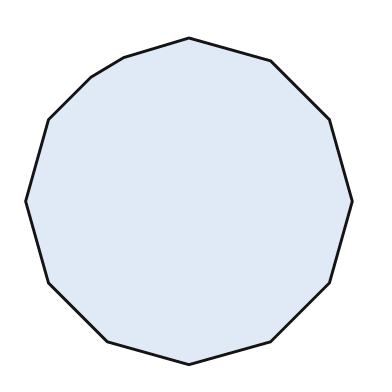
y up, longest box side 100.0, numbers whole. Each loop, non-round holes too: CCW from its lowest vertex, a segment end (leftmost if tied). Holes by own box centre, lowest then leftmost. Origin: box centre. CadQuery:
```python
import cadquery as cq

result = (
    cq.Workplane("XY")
    .moveTo(0.0, -50.0)
    .lineTo(25.0, -43.0)
    .lineTo(43.0, -25.0)
    .lineTo(50.0, 0.0)
    .lineTo(43.0, 25.0)
    .lineTo(25.0, 43.0)
    .lineTo(0.0, 50.0)
    .lineTo(-20.0, 44.0)
    .lineTo(-30.0, 38.0)
    .lineTo(-43.0, 25.0)
    .lineTo(-50.0, 0.0)
    .lineTo(-43.0, -25.0)
    .lineTo(-25.0, -43.0)
    .close()
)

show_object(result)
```